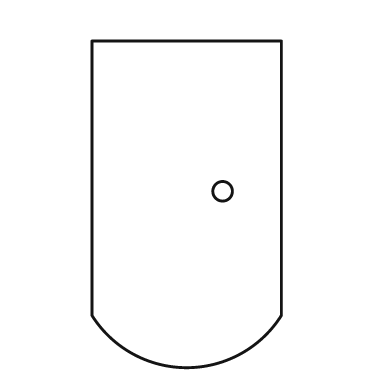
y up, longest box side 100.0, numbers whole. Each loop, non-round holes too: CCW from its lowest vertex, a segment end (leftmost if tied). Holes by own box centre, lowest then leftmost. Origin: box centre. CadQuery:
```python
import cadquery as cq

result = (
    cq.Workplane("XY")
    .moveTo(-29.0, -34.0)
    .threePointArc((0.0, -50.0), (29.0, -34.0))
    .lineTo(29.0, 50.0)
    .lineTo(-29.0, 50.0)
    .close()
    .moveTo(11.0, 4.0)
    .circle(3.0)
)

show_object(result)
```